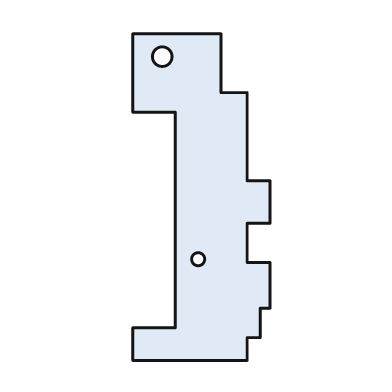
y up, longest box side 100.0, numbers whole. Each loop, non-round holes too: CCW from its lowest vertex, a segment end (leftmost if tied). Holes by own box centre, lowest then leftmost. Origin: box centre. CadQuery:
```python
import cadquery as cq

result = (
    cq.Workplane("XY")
    .moveTo(-21.0, -50.0)
    .lineTo(14.0, -50.0)
    .lineTo(14.0, -43.0)
    .lineTo(18.0, -43.0)
    .lineTo(18.0, -34.0)
    .lineTo(21.0, -34.0)
    .lineTo(21.0, -20.0)
    .lineTo(14.0, -20.0)
    .lineTo(14.0, -8.0)
    .lineTo(21.0, -8.0)
    .lineTo(21.0, 5.0)
    .lineTo(14.0, 5.0)
    .lineTo(14.0, 32.0)
    .lineTo(6.0, 32.0)
    .lineTo(6.0, 50.0)
    .lineTo(-21.0, 50.0)
    .lineTo(-21.0, 26.0)
    .lineTo(-8.0, 26.0)
    .lineTo(-8.0, -40.0)
    .lineTo(-21.0, -40.0)
    .close()
    .moveTo(-1.0, -19.0)
    .circle(2.0)
    .moveTo(-12.0, 43.0)
    .circle(3.0)
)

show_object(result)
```